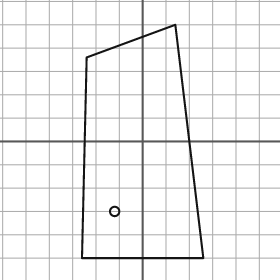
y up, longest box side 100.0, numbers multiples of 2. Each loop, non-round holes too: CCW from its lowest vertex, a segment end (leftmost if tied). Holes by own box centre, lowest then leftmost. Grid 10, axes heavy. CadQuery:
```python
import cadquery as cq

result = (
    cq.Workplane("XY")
    .moveTo(-26.0, -50.0)
    .lineTo(26.0, -50.0)
    .lineTo(14.0, 50.0)
    .lineTo(-24.0, 36.0)
    .close()
    .moveTo(-12.0, -30.0)
    .circle(2.0)
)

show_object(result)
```